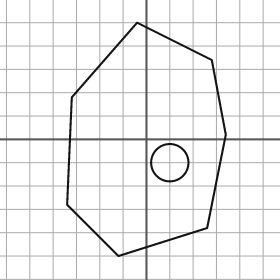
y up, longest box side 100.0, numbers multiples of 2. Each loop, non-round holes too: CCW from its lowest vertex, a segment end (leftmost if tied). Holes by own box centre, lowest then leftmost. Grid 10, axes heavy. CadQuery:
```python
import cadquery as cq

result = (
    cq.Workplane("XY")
    .moveTo(-12.0, -50.0)
    .lineTo(26.0, -38.0)
    .lineTo(34.0, 2.0)
    .lineTo(28.0, 34.0)
    .lineTo(-4.0, 50.0)
    .lineTo(-32.0, 18.0)
    .lineTo(-34.0, -28.0)
    .close()
    .moveTo(10.0, -10.0)
    .circle(8.0)
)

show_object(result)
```